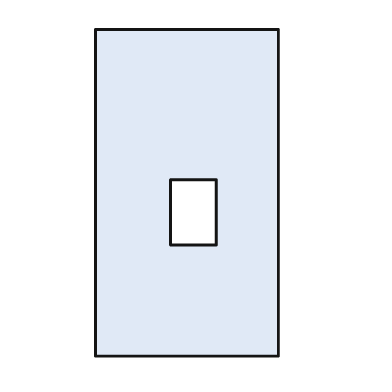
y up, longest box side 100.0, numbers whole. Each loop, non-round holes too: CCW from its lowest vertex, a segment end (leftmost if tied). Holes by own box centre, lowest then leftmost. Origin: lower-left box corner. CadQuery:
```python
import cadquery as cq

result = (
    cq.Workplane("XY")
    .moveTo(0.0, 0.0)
    .lineTo(56.0, 0.0)
    .lineTo(56.0, 100.0)
    .lineTo(0.0, 100.0)
    .close()
    .moveTo(23.0, 34.0)
    .lineTo(37.0, 34.0)
    .lineTo(37.0, 54.0)
    .lineTo(23.0, 54.0)
    .close()
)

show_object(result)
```